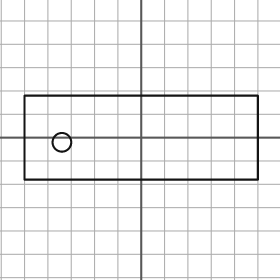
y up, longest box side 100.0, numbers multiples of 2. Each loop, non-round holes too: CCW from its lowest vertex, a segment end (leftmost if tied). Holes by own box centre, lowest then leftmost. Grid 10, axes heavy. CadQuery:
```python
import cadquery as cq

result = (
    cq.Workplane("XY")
    .moveTo(-50.0, -18.0)
    .lineTo(50.0, -18.0)
    .lineTo(50.0, 18.0)
    .lineTo(-50.0, 18.0)
    .close()
    .moveTo(-34.0, -2.0)
    .circle(4.0)
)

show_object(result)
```